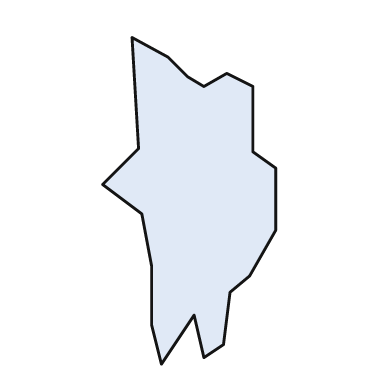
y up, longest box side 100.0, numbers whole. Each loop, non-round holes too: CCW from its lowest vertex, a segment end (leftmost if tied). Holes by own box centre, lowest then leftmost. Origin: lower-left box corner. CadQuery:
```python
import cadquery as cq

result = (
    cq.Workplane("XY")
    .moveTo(18.0, 0.0)
    .lineTo(28.0, 15.0)
    .lineTo(31.0, 2.0)
    .lineTo(37.0, 6.0)
    .lineTo(39.0, 22.0)
    .lineTo(45.0, 27.0)
    .lineTo(53.0, 41.0)
    .lineTo(53.0, 60.0)
    .lineTo(46.0, 65.0)
    .lineTo(46.0, 85.0)
    .lineTo(38.0, 89.0)
    .lineTo(31.0, 85.0)
    .lineTo(26.0, 88.0)
    .lineTo(20.0, 94.0)
    .lineTo(9.0, 100.0)
    .lineTo(11.0, 66.0)
    .lineTo(0.0, 55.0)
    .lineTo(12.0, 46.0)
    .lineTo(15.0, 30.0)
    .lineTo(15.0, 12.0)
    .close()
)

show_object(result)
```